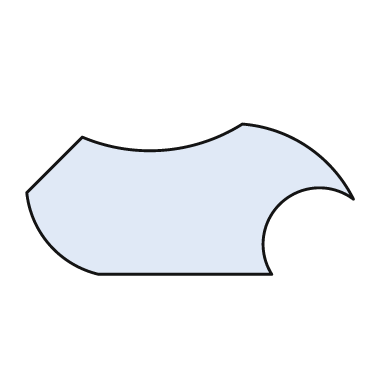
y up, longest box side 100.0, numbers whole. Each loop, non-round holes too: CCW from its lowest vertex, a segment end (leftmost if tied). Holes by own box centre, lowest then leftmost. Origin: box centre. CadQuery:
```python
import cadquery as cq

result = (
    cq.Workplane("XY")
    .moveTo(-28.0, -23.0)
    .lineTo(25.0, -23.0)
    .threePointArc((28.0, -1.0), (50.0, 0.0))
    .threePointArc((36.0, 16.0), (16.0, 23.0))
    .threePointArc((-8.0, 15.0), (-33.0, 19.0))
    .lineTo(-50.0, 2.0)
    .threePointArc((-43.0, -14.0), (-28.0, -23.0))
    .close()
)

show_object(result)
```